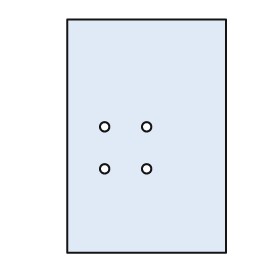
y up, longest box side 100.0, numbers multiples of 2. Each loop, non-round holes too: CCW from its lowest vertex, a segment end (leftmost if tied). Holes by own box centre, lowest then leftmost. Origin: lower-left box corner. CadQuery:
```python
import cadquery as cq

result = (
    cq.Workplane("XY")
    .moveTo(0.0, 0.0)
    .lineTo(68.0, 0.0)
    .lineTo(68.0, 100.0)
    .lineTo(0.0, 100.0)
    .close()
    .moveTo(16.0, 36.0)
    .circle(2.0)
    .moveTo(34.0, 36.0)
    .circle(2.0)
    .moveTo(16.0, 54.0)
    .circle(2.0)
    .moveTo(34.0, 54.0)
    .circle(2.0)
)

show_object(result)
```